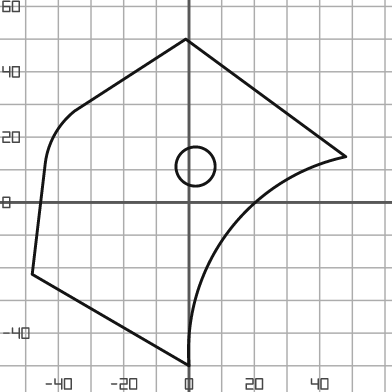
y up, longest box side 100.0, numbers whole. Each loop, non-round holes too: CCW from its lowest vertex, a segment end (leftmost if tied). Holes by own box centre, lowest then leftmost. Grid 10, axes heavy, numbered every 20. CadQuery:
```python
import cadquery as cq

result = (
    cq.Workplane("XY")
    .moveTo(0.0, -50.0)
    .threePointArc((12.0, -9.0), (48.0, 14.0))
    .lineTo(-1.0, 50.0)
    .lineTo(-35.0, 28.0)
    .threePointArc((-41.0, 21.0), (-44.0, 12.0))
    .lineTo(-48.0, -22.0)
    .close()
    .moveTo(2.0, 11.0)
    .circle(6.0)
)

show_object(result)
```